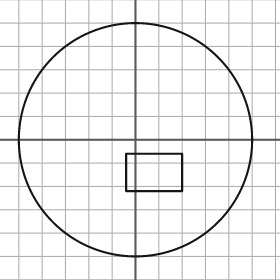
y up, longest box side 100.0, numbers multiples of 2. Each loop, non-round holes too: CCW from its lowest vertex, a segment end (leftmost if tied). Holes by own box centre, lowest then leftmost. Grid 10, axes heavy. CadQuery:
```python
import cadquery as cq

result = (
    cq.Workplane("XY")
    .moveTo(0.0, 0.0)
    .circle(50.0)
    .moveTo(-4.0, -22.0)
    .lineTo(20.0, -22.0)
    .lineTo(20.0, -6.0)
    .lineTo(-4.0, -6.0)
    .close()
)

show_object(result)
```